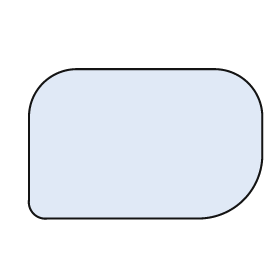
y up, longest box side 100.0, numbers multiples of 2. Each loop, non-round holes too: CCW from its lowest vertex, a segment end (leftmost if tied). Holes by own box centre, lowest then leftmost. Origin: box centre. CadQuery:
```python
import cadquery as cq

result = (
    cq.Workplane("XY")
    .moveTo(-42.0, -32.0)
    .lineTo(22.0, -32.0)
    .threePointArc((42.0, -24.0), (50.0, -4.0))
    .lineTo(50.0, 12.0)
    .threePointArc((44.0, 26.0), (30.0, 32.0))
    .lineTo(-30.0, 32.0)
    .threePointArc((-44.0, 26.0), (-50.0, 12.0))
    .lineTo(-50.0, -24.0)
    .threePointArc((-48.0, -30.0), (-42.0, -32.0))
    .close()
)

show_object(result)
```